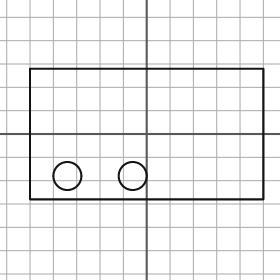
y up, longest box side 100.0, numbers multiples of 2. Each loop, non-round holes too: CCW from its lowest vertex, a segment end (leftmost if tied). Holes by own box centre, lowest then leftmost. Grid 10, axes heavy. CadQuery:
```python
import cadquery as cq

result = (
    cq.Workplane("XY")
    .moveTo(-50.0, -28.0)
    .lineTo(50.0, -28.0)
    .lineTo(50.0, 28.0)
    .lineTo(-50.0, 28.0)
    .close()
    .moveTo(-34.0, -18.0)
    .circle(6.0)
    .moveTo(-6.0, -18.0)
    .circle(6.0)
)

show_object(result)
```